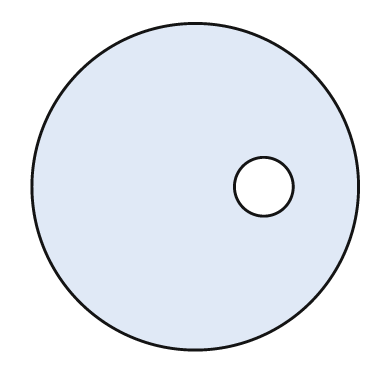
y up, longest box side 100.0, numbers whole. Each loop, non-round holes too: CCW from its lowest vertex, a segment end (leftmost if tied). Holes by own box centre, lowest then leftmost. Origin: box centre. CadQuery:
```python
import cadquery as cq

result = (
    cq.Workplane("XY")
    .moveTo(0.0, 0.0)
    .circle(50.0)
    .moveTo(21.0, 0.0)
    .circle(9.0)
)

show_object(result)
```